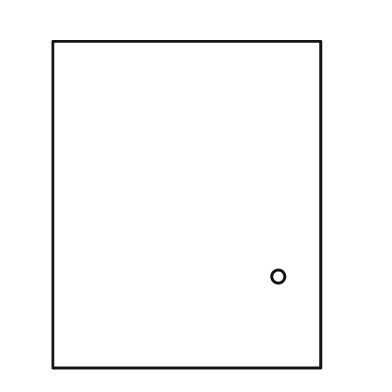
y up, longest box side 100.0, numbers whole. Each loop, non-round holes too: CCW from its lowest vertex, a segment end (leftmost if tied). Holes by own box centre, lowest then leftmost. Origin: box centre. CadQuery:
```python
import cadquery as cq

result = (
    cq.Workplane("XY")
    .moveTo(-41.0, -50.0)
    .lineTo(41.0, -50.0)
    .lineTo(41.0, 50.0)
    .lineTo(-41.0, 50.0)
    .close()
    .moveTo(28.0, -22.0)
    .circle(2.0)
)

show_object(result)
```